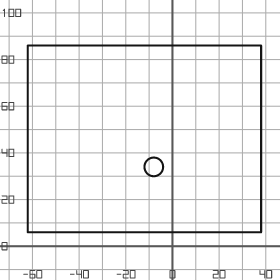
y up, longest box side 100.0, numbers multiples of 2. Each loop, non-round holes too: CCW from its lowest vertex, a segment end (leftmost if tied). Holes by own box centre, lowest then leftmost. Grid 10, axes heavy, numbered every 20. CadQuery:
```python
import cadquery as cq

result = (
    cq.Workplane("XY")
    .moveTo(-62.0, 6.0)
    .lineTo(38.0, 6.0)
    .lineTo(38.0, 86.0)
    .lineTo(-62.0, 86.0)
    .close()
    .moveTo(-8.0, 34.0)
    .circle(4.0)
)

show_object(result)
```